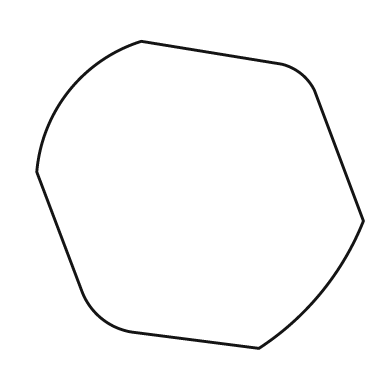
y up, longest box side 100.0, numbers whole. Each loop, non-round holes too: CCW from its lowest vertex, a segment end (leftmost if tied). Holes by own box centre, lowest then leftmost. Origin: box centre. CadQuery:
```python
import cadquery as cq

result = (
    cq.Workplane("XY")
    .moveTo(18.0, -47.0)
    .threePointArc((37.0, -30.0), (50.0, -8.0))
    .lineTo(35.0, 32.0)
    .threePointArc((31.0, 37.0), (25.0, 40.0))
    .lineTo(-18.0, 47.0)
    .threePointArc((-40.0, 32.0), (-50.0, 7.0))
    .lineTo(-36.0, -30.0)
    .threePointArc((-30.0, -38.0), (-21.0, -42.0))
    .close()
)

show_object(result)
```